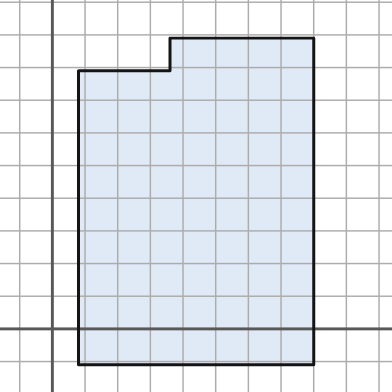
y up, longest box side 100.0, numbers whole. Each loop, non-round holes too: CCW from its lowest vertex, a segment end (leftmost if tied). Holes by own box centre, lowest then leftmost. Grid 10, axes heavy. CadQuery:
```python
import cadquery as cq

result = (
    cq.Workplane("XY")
    .moveTo(8.0, -11.0)
    .lineTo(80.0, -11.0)
    .lineTo(80.0, 89.0)
    .lineTo(36.0, 89.0)
    .lineTo(36.0, 79.0)
    .lineTo(8.0, 79.0)
    .close()
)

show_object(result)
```